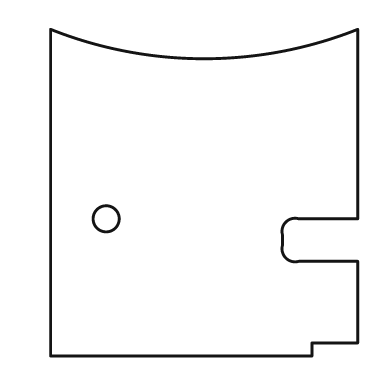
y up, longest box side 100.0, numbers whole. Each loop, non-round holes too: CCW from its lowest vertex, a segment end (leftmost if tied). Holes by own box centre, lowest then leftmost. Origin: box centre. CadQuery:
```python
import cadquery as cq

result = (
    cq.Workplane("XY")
    .moveTo(-47.0, -50.0)
    .lineTo(33.0, -50.0)
    .lineTo(33.0, -46.0)
    .lineTo(47.0, -46.0)
    .lineTo(47.0, -21.0)
    .lineTo(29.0, -21.0)
    .threePointArc((25.0, -20.0), (24.0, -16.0))
    .lineTo(24.0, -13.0)
    .threePointArc((25.0, -9.0), (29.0, -8.0))
    .lineTo(47.0, -8.0)
    .lineTo(47.0, 50.0)
    .threePointArc((0.0, 41.0), (-47.0, 50.0))
    .close()
    .moveTo(-30.0, -8.0)
    .circle(4.0)
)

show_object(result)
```